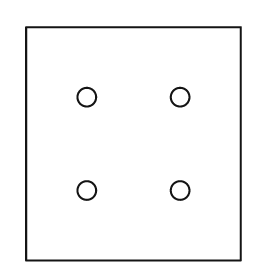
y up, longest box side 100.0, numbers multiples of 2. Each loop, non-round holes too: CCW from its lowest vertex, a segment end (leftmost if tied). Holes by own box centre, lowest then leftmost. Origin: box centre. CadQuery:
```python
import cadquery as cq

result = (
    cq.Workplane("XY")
    .moveTo(-46.0, -50.0)
    .lineTo(46.0, -50.0)
    .lineTo(46.0, 50.0)
    .lineTo(-46.0, 50.0)
    .close()
    .moveTo(-20.0, -20.0)
    .circle(4.0)
    .moveTo(20.0, -20.0)
    .circle(4.0)
    .moveTo(-20.0, 20.0)
    .circle(4.0)
    .moveTo(20.0, 20.0)
    .circle(4.0)
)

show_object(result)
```